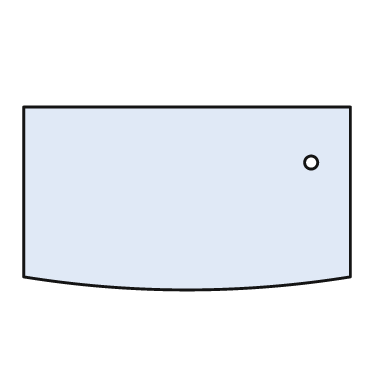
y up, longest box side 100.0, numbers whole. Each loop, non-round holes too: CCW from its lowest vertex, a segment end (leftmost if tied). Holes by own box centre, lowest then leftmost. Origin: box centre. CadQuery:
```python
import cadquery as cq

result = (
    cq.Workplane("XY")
    .moveTo(-50.0, -24.0)
    .threePointArc((0.0, -28.0), (50.0, -24.0))
    .lineTo(50.0, 28.0)
    .lineTo(-50.0, 28.0)
    .close()
    .moveTo(38.0, 11.0)
    .circle(2.0)
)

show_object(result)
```